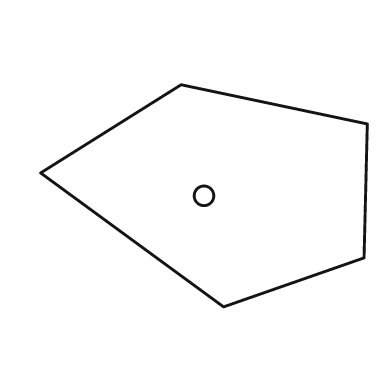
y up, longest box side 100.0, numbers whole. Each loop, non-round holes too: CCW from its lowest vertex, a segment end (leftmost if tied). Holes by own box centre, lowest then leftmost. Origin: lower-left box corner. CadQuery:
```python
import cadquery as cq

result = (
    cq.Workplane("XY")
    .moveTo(56.0, 0.0)
    .lineTo(99.0, 15.0)
    .lineTo(100.0, 56.0)
    .lineTo(43.0, 68.0)
    .lineTo(0.0, 41.0)
    .close()
    .moveTo(50.0, 34.0)
    .circle(3.0)
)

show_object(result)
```